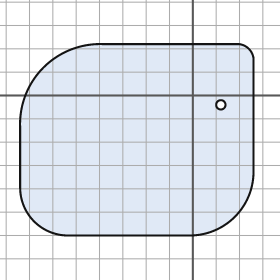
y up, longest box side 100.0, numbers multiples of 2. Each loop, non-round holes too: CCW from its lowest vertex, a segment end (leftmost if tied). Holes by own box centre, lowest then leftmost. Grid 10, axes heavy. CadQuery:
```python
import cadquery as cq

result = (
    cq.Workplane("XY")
    .moveTo(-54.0, -60.0)
    .lineTo(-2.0, -60.0)
    .threePointArc((18.0, -52.0), (26.0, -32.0))
    .lineTo(26.0, 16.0)
    .threePointArc((24.0, 20.0), (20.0, 22.0))
    .lineTo(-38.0, 22.0)
    .threePointArc((-64.0, 12.0), (-74.0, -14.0))
    .lineTo(-74.0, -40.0)
    .threePointArc((-68.0, -54.0), (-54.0, -60.0))
    .close()
    .moveTo(12.0, -4.0)
    .circle(2.0)
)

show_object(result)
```